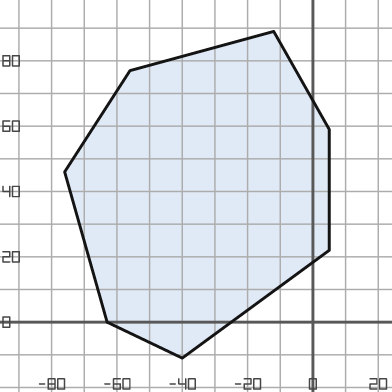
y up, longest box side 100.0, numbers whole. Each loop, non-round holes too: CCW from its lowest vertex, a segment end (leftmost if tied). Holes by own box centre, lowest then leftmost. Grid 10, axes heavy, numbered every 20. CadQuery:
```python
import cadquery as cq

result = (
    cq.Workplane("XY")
    .moveTo(-40.0, -11.0)
    .lineTo(5.0, 22.0)
    .lineTo(5.0, 59.0)
    .lineTo(-12.0, 89.0)
    .lineTo(-56.0, 77.0)
    .lineTo(-76.0, 46.0)
    .lineTo(-63.0, 0.0)
    .close()
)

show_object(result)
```